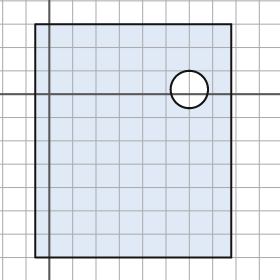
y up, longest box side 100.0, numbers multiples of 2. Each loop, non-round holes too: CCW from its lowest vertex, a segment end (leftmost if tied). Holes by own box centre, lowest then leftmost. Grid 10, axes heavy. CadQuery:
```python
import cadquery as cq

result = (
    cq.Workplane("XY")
    .moveTo(-6.0, -70.0)
    .lineTo(78.0, -70.0)
    .lineTo(78.0, 30.0)
    .lineTo(-6.0, 30.0)
    .close()
    .moveTo(60.0, 2.0)
    .circle(8.0)
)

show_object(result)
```